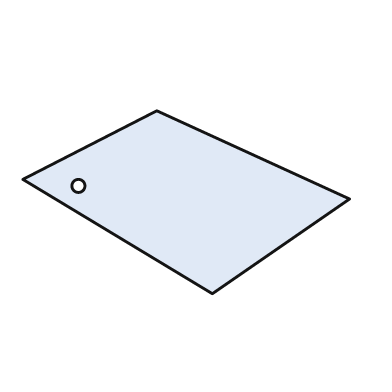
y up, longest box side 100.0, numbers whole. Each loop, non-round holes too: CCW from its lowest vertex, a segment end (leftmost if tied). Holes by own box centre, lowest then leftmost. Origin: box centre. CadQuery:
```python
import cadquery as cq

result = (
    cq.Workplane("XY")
    .moveTo(8.0, -28.0)
    .lineTo(50.0, 1.0)
    .lineTo(-9.0, 28.0)
    .lineTo(-50.0, 7.0)
    .close()
    .moveTo(-33.0, 5.0)
    .circle(2.0)
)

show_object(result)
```